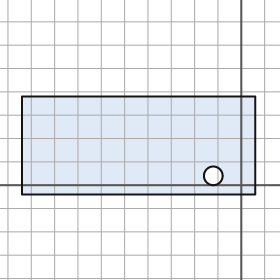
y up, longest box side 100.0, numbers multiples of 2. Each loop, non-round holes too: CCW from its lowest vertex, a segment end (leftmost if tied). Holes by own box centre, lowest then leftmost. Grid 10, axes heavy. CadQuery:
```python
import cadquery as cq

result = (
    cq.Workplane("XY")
    .moveTo(-94.0, -4.0)
    .lineTo(6.0, -4.0)
    .lineTo(6.0, 38.0)
    .lineTo(-94.0, 38.0)
    .close()
    .moveTo(-12.0, 4.0)
    .circle(4.0)
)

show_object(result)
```